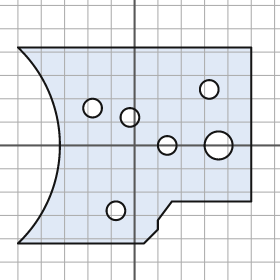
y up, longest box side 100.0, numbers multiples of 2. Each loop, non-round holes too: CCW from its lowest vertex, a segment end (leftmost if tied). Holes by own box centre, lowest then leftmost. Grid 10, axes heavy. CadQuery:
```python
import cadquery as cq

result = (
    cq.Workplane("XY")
    .moveTo(-50.0, -42.0)
    .lineTo(4.0, -42.0)
    .lineTo(10.0, -36.0)
    .lineTo(10.0, -32.0)
    .lineTo(16.0, -24.0)
    .lineTo(50.0, -24.0)
    .lineTo(50.0, 42.0)
    .lineTo(-50.0, 42.0)
    .threePointArc((-32.0, 0.0), (-50.0, -42.0))
    .close()
    .moveTo(-8.0, -28.0)
    .circle(4.0)
    .moveTo(14.0, 0.0)
    .circle(4.0)
    .moveTo(36.0, 0.0)
    .circle(6.0)
    .moveTo(-2.0, 12.0)
    .circle(4.0)
    .moveTo(-18.0, 16.0)
    .circle(4.0)
    .moveTo(32.0, 24.0)
    .circle(4.0)
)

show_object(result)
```